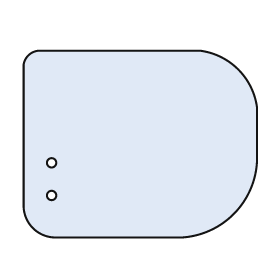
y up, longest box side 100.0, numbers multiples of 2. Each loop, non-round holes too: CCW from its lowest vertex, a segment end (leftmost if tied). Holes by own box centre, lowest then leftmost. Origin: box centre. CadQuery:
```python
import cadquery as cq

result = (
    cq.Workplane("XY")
    .moveTo(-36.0, -40.0)
    .lineTo(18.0, -40.0)
    .threePointArc((40.0, -30.0), (50.0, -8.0))
    .lineTo(50.0, 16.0)
    .threePointArc((42.0, 32.0), (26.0, 40.0))
    .lineTo(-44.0, 40.0)
    .threePointArc((-48.0, 38.0), (-50.0, 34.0))
    .lineTo(-50.0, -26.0)
    .threePointArc((-46.0, -36.0), (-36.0, -40.0))
    .close()
    .moveTo(-38.0, -22.0)
    .circle(2.0)
    .moveTo(-38.0, -8.0)
    .circle(2.0)
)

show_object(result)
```